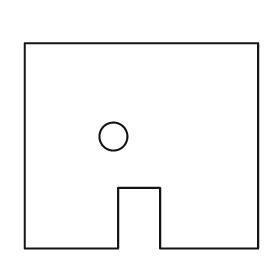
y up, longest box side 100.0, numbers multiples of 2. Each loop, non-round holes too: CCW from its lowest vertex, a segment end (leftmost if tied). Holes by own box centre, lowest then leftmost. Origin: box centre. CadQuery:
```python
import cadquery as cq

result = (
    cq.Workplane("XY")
    .moveTo(-50.0, -44.0)
    .lineTo(-10.0, -44.0)
    .lineTo(-10.0, -18.0)
    .lineTo(8.0, -18.0)
    .lineTo(8.0, -44.0)
    .lineTo(50.0, -44.0)
    .lineTo(50.0, 44.0)
    .lineTo(-50.0, 44.0)
    .close()
    .moveTo(-12.0, 4.0)
    .circle(6.0)
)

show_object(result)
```